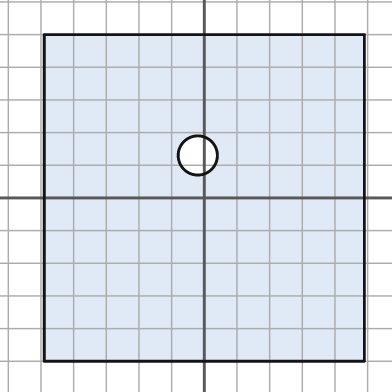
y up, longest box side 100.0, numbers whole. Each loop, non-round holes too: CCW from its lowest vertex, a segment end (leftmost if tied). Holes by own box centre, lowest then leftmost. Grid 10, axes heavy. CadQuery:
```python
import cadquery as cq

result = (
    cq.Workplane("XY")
    .moveTo(-49.0, -50.0)
    .lineTo(49.0, -50.0)
    .lineTo(49.0, 50.0)
    .lineTo(-49.0, 50.0)
    .close()
    .moveTo(-2.0, 13.0)
    .circle(6.0)
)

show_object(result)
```